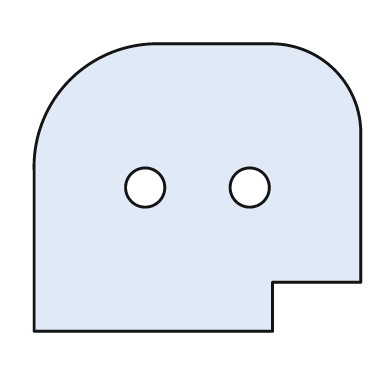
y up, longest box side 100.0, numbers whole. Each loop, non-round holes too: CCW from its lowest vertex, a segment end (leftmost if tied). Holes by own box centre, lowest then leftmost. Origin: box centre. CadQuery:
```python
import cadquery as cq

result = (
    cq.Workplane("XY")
    .moveTo(-50.0, -44.0)
    .lineTo(23.0, -44.0)
    .lineTo(23.0, -29.0)
    .lineTo(50.0, -29.0)
    .lineTo(50.0, 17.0)
    .threePointArc((42.0, 36.0), (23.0, 44.0))
    .lineTo(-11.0, 44.0)
    .threePointArc((-39.0, 33.0), (-50.0, 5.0))
    .close()
    .moveTo(-16.0, 0.0)
    .circle(6.0)
    .moveTo(16.0, 0.0)
    .circle(6.0)
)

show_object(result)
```